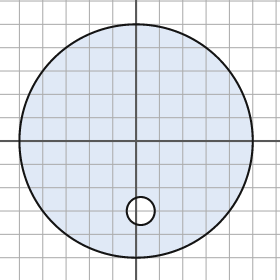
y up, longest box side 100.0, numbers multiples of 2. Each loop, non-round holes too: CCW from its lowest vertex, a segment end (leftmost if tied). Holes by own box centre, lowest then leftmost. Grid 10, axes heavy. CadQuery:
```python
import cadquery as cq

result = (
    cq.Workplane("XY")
    .moveTo(0.0, 0.0)
    .circle(50.0)
    .moveTo(2.0, -30.0)
    .circle(6.0)
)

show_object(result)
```